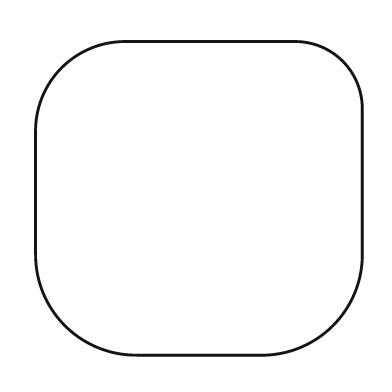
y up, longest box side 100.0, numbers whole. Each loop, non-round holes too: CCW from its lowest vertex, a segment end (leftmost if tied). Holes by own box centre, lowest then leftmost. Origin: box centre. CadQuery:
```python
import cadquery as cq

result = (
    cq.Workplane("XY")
    .moveTo(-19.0, -48.0)
    .lineTo(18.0, -48.0)
    .threePointArc((41.0, -39.0), (50.0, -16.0))
    .lineTo(50.0, 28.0)
    .threePointArc((44.0, 42.0), (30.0, 48.0))
    .lineTo(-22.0, 48.0)
    .threePointArc((-42.0, 40.0), (-50.0, 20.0))
    .lineTo(-50.0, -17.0)
    .threePointArc((-41.0, -39.0), (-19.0, -48.0))
    .close()
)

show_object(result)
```